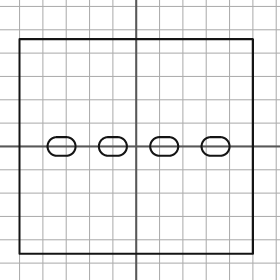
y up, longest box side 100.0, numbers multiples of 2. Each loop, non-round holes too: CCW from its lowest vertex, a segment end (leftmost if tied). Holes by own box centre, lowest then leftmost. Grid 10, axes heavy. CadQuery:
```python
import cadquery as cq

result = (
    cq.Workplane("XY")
    .moveTo(-50.0, -46.0)
    .lineTo(50.0, -46.0)
    .lineTo(50.0, 46.0)
    .lineTo(-50.0, 46.0)
    .close()
    .moveTo(-34.0, -4.0)
    .lineTo(-30.0, -4.0)
    .threePointArc((-26.0, 0.0), (-30.0, 4.0))
    .lineTo(-34.0, 4.0)
    .threePointArc((-38.0, 0.0), (-34.0, -4.0))
    .close()
    .moveTo(-12.0, -4.0)
    .lineTo(-8.0, -4.0)
    .threePointArc((-4.0, 0.0), (-8.0, 4.0))
    .lineTo(-12.0, 4.0)
    .threePointArc((-16.0, 0.0), (-12.0, -4.0))
    .close()
    .moveTo(10.0, -4.0)
    .lineTo(14.0, -4.0)
    .threePointArc((18.0, 0.0), (14.0, 4.0))
    .lineTo(10.0, 4.0)
    .threePointArc((6.0, 0.0), (10.0, -4.0))
    .close()
    .moveTo(32.0, -4.0)
    .lineTo(36.0, -4.0)
    .threePointArc((40.0, 0.0), (36.0, 4.0))
    .lineTo(32.0, 4.0)
    .threePointArc((28.0, 0.0), (32.0, -4.0))
    .close()
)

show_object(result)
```